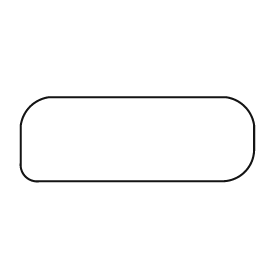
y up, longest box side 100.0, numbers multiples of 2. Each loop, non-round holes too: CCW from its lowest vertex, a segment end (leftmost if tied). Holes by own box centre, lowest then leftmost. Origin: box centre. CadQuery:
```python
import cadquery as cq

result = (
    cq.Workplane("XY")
    .moveTo(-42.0, -18.0)
    .lineTo(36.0, -18.0)
    .threePointArc((46.0, -14.0), (50.0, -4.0))
    .lineTo(50.0, 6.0)
    .threePointArc((46.0, 14.0), (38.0, 18.0))
    .lineTo(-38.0, 18.0)
    .threePointArc((-46.0, 14.0), (-50.0, 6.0))
    .lineTo(-50.0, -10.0)
    .threePointArc((-48.0, -16.0), (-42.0, -18.0))
    .close()
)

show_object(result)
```